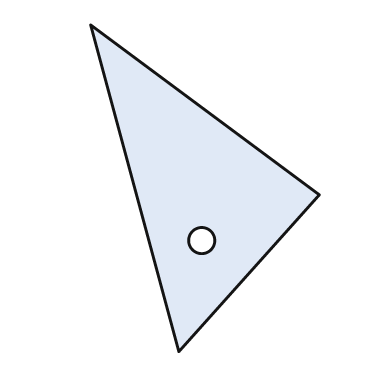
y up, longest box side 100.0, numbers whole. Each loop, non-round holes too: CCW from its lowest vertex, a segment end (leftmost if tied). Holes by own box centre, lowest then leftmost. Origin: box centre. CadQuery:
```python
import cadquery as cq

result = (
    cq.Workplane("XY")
    .moveTo(-8.0, -50.0)
    .lineTo(35.0, -2.0)
    .lineTo(-35.0, 50.0)
    .close()
    .moveTo(-1.0, -16.0)
    .circle(4.0)
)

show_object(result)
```